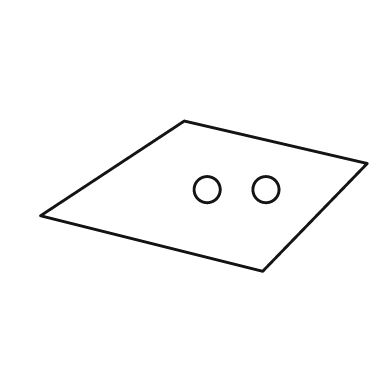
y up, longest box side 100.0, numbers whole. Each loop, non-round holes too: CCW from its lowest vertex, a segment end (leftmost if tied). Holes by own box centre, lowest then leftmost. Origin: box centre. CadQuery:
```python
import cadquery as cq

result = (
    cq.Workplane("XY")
    .moveTo(18.0, -23.0)
    .lineTo(50.0, 10.0)
    .lineTo(-6.0, 23.0)
    .lineTo(-50.0, -6.0)
    .close()
    .moveTo(1.0, 2.0)
    .circle(4.0)
    .moveTo(19.0, 2.0)
    .circle(4.0)
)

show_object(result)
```